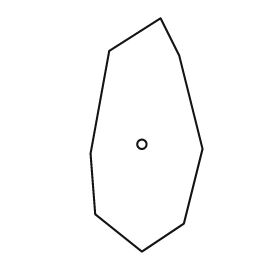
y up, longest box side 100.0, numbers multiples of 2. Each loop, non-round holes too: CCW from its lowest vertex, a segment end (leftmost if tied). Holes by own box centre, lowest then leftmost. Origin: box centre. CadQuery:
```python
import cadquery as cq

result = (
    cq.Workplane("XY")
    .moveTo(-2.0, -50.0)
    .lineTo(16.0, -38.0)
    .lineTo(24.0, -6.0)
    .lineTo(14.0, 34.0)
    .lineTo(6.0, 50.0)
    .lineTo(-16.0, 36.0)
    .lineTo(-24.0, -8.0)
    .lineTo(-22.0, -34.0)
    .close()
    .moveTo(-2.0, -4.0)
    .circle(2.0)
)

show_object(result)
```